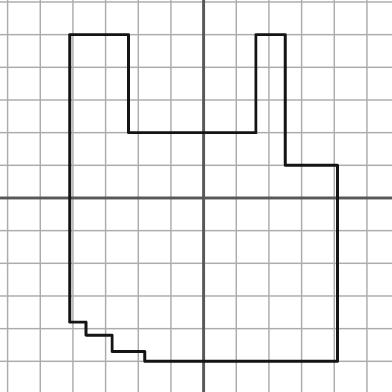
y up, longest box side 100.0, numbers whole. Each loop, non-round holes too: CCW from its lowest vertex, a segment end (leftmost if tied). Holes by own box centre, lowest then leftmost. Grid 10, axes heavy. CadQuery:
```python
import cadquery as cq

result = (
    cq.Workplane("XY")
    .moveTo(-18.0, -50.0)
    .lineTo(41.0, -50.0)
    .lineTo(41.0, 10.0)
    .lineTo(25.0, 10.0)
    .lineTo(25.0, 50.0)
    .lineTo(16.0, 50.0)
    .lineTo(16.0, 20.0)
    .lineTo(-23.0, 20.0)
    .lineTo(-23.0, 50.0)
    .lineTo(-41.0, 50.0)
    .lineTo(-41.0, -38.0)
    .lineTo(-36.0, -38.0)
    .lineTo(-36.0, -42.0)
    .lineTo(-28.0, -42.0)
    .lineTo(-28.0, -47.0)
    .lineTo(-18.0, -47.0)
    .close()
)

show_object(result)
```